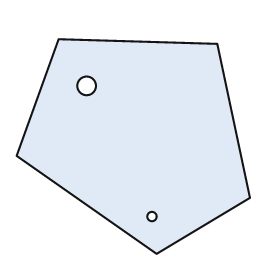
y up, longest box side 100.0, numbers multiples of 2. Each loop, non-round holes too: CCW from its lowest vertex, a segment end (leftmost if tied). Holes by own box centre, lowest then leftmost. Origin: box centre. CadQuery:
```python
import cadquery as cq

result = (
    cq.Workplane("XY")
    .moveTo(10.0, -46.0)
    .lineTo(50.0, -22.0)
    .lineTo(36.0, 44.0)
    .lineTo(-32.0, 46.0)
    .lineTo(-50.0, -4.0)
    .close()
    .moveTo(8.0, -30.0)
    .circle(2.0)
    .moveTo(-20.0, 26.0)
    .circle(4.0)
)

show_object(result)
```